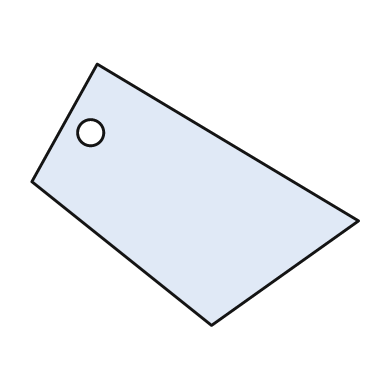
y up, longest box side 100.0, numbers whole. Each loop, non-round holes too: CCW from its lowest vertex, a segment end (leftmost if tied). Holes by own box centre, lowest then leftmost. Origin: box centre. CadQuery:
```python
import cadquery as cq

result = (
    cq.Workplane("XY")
    .moveTo(5.0, -40.0)
    .lineTo(50.0, -8.0)
    .lineTo(-30.0, 40.0)
    .lineTo(-50.0, 4.0)
    .close()
    .moveTo(-32.0, 19.0)
    .circle(4.0)
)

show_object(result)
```